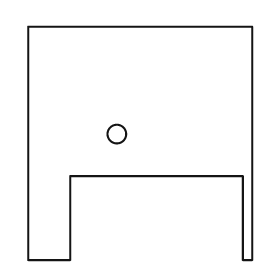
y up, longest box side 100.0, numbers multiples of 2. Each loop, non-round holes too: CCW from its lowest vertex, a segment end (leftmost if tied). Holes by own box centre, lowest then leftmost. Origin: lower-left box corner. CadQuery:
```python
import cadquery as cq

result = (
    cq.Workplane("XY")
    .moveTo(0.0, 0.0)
    .lineTo(18.0, 0.0)
    .lineTo(18.0, 36.0)
    .lineTo(92.0, 36.0)
    .lineTo(92.0, 0.0)
    .lineTo(96.0, 0.0)
    .lineTo(96.0, 100.0)
    .lineTo(0.0, 100.0)
    .close()
    .moveTo(38.0, 54.0)
    .circle(4.0)
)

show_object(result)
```